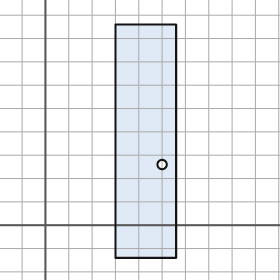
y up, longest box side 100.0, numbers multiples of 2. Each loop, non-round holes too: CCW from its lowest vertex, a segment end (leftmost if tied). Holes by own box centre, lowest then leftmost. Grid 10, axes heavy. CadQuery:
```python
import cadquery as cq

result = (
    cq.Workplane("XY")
    .moveTo(30.0, -14.0)
    .lineTo(56.0, -14.0)
    .lineTo(56.0, 86.0)
    .lineTo(30.0, 86.0)
    .close()
    .moveTo(50.0, 26.0)
    .circle(2.0)
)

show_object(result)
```